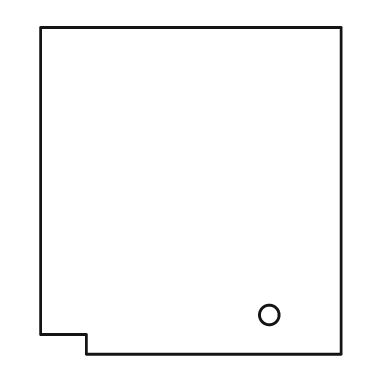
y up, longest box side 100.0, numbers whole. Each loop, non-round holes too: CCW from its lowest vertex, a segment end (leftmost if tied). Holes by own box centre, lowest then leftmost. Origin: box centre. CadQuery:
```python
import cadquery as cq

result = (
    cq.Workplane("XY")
    .moveTo(-32.0, -50.0)
    .lineTo(46.0, -50.0)
    .lineTo(46.0, 50.0)
    .lineTo(-46.0, 50.0)
    .lineTo(-46.0, -44.0)
    .lineTo(-32.0, -44.0)
    .close()
    .moveTo(24.0, -38.0)
    .circle(3.0)
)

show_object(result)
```